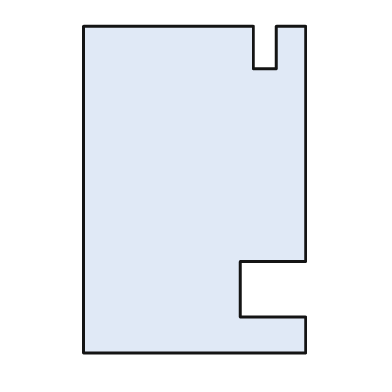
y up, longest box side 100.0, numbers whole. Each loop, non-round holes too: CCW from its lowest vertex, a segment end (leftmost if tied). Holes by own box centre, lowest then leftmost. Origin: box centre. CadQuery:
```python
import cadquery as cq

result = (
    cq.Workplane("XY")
    .moveTo(-34.0, -50.0)
    .lineTo(34.0, -50.0)
    .lineTo(34.0, -39.0)
    .lineTo(14.0, -39.0)
    .lineTo(14.0, -22.0)
    .lineTo(34.0, -22.0)
    .lineTo(34.0, 50.0)
    .lineTo(25.0, 50.0)
    .lineTo(25.0, 37.0)
    .lineTo(18.0, 37.0)
    .lineTo(18.0, 50.0)
    .lineTo(-34.0, 50.0)
    .close()
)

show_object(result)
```